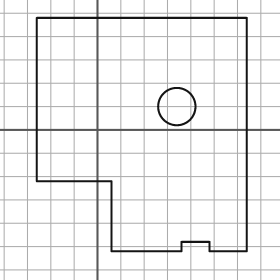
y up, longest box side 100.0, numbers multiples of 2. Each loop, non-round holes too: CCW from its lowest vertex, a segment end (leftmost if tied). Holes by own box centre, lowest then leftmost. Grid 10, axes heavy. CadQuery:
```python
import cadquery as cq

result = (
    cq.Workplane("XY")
    .moveTo(6.0, -52.0)
    .lineTo(36.0, -52.0)
    .lineTo(36.0, -48.0)
    .lineTo(48.0, -48.0)
    .lineTo(48.0, -52.0)
    .lineTo(64.0, -52.0)
    .lineTo(64.0, 48.0)
    .lineTo(-26.0, 48.0)
    .lineTo(-26.0, -22.0)
    .lineTo(6.0, -22.0)
    .close()
    .moveTo(34.0, 10.0)
    .circle(8.0)
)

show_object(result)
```